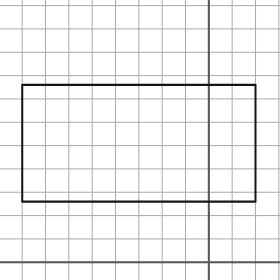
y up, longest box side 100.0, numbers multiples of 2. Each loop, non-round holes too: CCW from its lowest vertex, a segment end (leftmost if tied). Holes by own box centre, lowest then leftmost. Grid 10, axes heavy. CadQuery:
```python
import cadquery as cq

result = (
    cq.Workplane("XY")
    .moveTo(-80.0, 26.0)
    .lineTo(20.0, 26.0)
    .lineTo(20.0, 76.0)
    .lineTo(-80.0, 76.0)
    .close()
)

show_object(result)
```